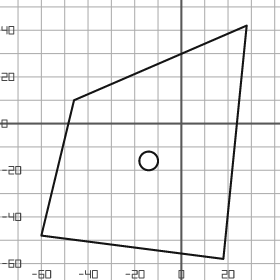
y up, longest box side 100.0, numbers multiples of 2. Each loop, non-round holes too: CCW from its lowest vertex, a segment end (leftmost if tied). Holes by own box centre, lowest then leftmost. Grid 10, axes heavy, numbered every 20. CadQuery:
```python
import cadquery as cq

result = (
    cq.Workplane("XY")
    .moveTo(18.0, -58.0)
    .lineTo(28.0, 42.0)
    .lineTo(-46.0, 10.0)
    .lineTo(-60.0, -48.0)
    .close()
    .moveTo(-14.0, -16.0)
    .circle(4.0)
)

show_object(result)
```